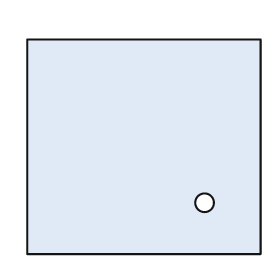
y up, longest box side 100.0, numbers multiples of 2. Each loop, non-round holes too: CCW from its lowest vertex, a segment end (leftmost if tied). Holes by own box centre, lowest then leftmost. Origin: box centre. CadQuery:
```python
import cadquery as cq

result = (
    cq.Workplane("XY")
    .moveTo(-50.0, -46.0)
    .lineTo(50.0, -46.0)
    .lineTo(50.0, 46.0)
    .lineTo(-50.0, 46.0)
    .close()
    .moveTo(26.0, -24.0)
    .circle(4.0)
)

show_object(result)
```